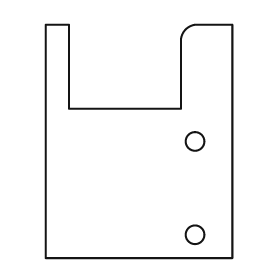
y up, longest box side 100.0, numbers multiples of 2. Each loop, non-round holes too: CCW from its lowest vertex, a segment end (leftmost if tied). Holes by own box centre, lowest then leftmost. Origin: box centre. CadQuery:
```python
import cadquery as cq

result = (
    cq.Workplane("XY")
    .moveTo(-40.0, -50.0)
    .lineTo(40.0, -50.0)
    .lineTo(40.0, 50.0)
    .lineTo(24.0, 50.0)
    .threePointArc((20.0, 48.0), (18.0, 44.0))
    .lineTo(18.0, 14.0)
    .lineTo(-30.0, 14.0)
    .lineTo(-30.0, 50.0)
    .lineTo(-40.0, 50.0)
    .close()
    .moveTo(24.0, -40.0)
    .circle(4.0)
    .moveTo(24.0, 0.0)
    .circle(4.0)
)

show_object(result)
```